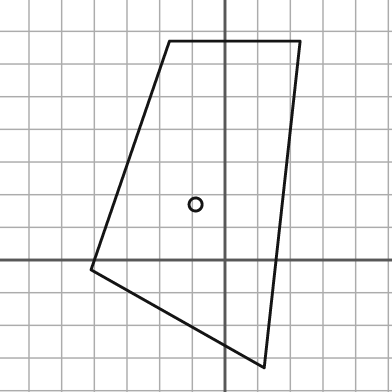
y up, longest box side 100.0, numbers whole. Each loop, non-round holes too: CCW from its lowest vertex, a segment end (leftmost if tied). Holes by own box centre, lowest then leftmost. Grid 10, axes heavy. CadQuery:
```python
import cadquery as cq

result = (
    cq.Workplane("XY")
    .moveTo(12.0, -33.0)
    .lineTo(23.0, 67.0)
    .lineTo(-17.0, 67.0)
    .lineTo(-41.0, -3.0)
    .close()
    .moveTo(-9.0, 17.0)
    .circle(2.0)
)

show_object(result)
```